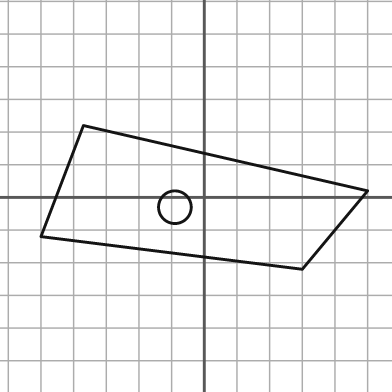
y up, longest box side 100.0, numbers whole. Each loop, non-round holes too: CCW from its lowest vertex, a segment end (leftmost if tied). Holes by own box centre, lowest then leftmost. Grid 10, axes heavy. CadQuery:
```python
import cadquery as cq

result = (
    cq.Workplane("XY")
    .moveTo(30.0, -22.0)
    .lineTo(50.0, 2.0)
    .lineTo(-37.0, 22.0)
    .lineTo(-50.0, -12.0)
    .close()
    .moveTo(-9.0, -3.0)
    .circle(5.0)
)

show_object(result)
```